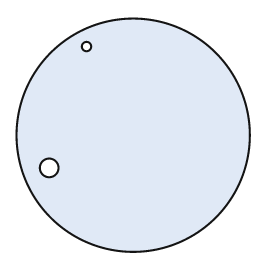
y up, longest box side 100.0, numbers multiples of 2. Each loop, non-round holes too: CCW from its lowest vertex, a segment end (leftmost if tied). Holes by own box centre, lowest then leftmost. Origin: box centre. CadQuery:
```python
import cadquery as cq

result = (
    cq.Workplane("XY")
    .moveTo(0.0, 0.0)
    .circle(50.0)
    .moveTo(-36.0, -14.0)
    .circle(4.0)
    .moveTo(-20.0, 38.0)
    .circle(2.0)
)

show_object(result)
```